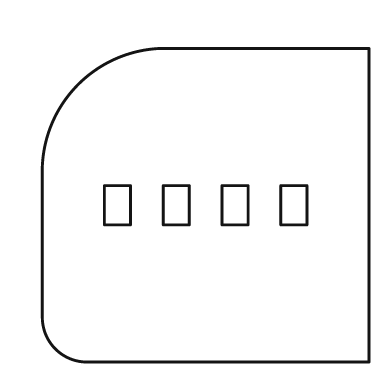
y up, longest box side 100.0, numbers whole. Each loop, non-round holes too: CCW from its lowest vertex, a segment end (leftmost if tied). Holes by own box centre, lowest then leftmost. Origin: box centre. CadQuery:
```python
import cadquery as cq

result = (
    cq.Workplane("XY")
    .moveTo(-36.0, -48.0)
    .lineTo(50.0, -48.0)
    .lineTo(50.0, 48.0)
    .lineTo(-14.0, 48.0)
    .threePointArc((-39.0, 37.0), (-50.0, 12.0))
    .lineTo(-50.0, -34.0)
    .threePointArc((-46.0, -44.0), (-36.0, -48.0))
    .close()
    .moveTo(-31.0, -6.0)
    .lineTo(-23.0, -6.0)
    .lineTo(-23.0, 6.0)
    .lineTo(-31.0, 6.0)
    .close()
    .moveTo(-13.0, -6.0)
    .lineTo(-5.0, -6.0)
    .lineTo(-5.0, 6.0)
    .lineTo(-13.0, 6.0)
    .close()
    .moveTo(5.0, -6.0)
    .lineTo(13.0, -6.0)
    .lineTo(13.0, 6.0)
    .lineTo(5.0, 6.0)
    .close()
    .moveTo(23.0, -6.0)
    .lineTo(31.0, -6.0)
    .lineTo(31.0, 6.0)
    .lineTo(23.0, 6.0)
    .close()
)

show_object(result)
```